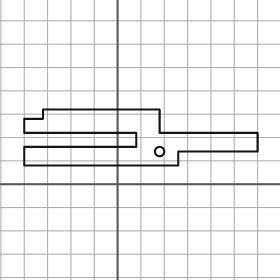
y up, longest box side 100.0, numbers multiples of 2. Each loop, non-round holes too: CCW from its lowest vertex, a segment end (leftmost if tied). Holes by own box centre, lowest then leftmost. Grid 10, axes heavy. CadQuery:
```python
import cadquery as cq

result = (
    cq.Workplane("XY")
    .moveTo(-40.0, 8.0)
    .lineTo(26.0, 8.0)
    .lineTo(26.0, 14.0)
    .lineTo(60.0, 14.0)
    .lineTo(60.0, 22.0)
    .lineTo(18.0, 22.0)
    .lineTo(18.0, 32.0)
    .lineTo(-32.0, 32.0)
    .lineTo(-32.0, 28.0)
    .lineTo(-40.0, 28.0)
    .lineTo(-40.0, 22.0)
    .lineTo(8.0, 22.0)
    .lineTo(8.0, 16.0)
    .lineTo(-40.0, 16.0)
    .close()
    .moveTo(18.0, 14.0)
    .circle(2.0)
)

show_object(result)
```